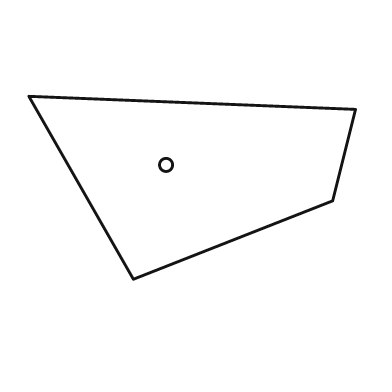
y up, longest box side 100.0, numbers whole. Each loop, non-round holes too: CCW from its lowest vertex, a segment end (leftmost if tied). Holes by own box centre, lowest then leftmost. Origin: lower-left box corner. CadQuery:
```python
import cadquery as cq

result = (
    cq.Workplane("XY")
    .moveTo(32.0, 0.0)
    .lineTo(93.0, 24.0)
    .lineTo(100.0, 52.0)
    .lineTo(0.0, 56.0)
    .close()
    .moveTo(42.0, 35.0)
    .circle(2.0)
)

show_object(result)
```